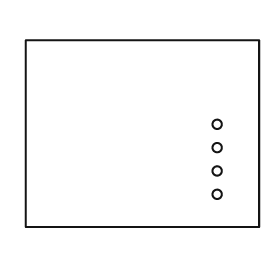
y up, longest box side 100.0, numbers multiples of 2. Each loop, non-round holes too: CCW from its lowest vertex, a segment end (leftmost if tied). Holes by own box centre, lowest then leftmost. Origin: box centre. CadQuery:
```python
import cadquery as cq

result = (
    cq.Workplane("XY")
    .moveTo(-50.0, -40.0)
    .lineTo(50.0, -40.0)
    .lineTo(50.0, 40.0)
    .lineTo(-50.0, 40.0)
    .close()
    .moveTo(32.0, -26.0)
    .circle(2.0)
    .moveTo(32.0, -16.0)
    .circle(2.0)
    .moveTo(32.0, -6.0)
    .circle(2.0)
    .moveTo(32.0, 4.0)
    .circle(2.0)
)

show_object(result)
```